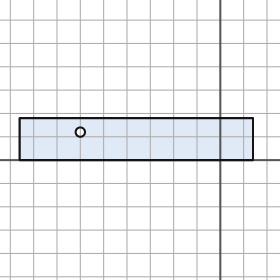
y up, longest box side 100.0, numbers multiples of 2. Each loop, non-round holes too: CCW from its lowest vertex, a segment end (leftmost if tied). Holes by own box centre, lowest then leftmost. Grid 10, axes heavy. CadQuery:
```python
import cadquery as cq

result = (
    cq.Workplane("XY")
    .moveTo(-86.0, 0.0)
    .lineTo(14.0, 0.0)
    .lineTo(14.0, 18.0)
    .lineTo(-86.0, 18.0)
    .close()
    .moveTo(-60.0, 12.0)
    .circle(2.0)
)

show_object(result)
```